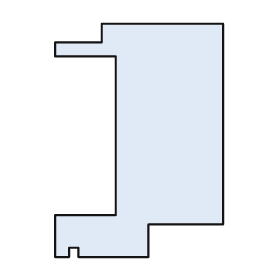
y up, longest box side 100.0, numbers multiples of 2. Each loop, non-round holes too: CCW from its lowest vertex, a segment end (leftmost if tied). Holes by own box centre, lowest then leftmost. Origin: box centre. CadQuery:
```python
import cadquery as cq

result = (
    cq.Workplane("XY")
    .moveTo(-36.0, -50.0)
    .lineTo(-30.0, -50.0)
    .lineTo(-30.0, -46.0)
    .lineTo(-26.0, -46.0)
    .lineTo(-26.0, -50.0)
    .lineTo(4.0, -50.0)
    .lineTo(4.0, -36.0)
    .lineTo(36.0, -36.0)
    .lineTo(36.0, 50.0)
    .lineTo(-16.0, 50.0)
    .lineTo(-16.0, 42.0)
    .lineTo(-36.0, 42.0)
    .lineTo(-36.0, 36.0)
    .lineTo(-10.0, 36.0)
    .lineTo(-10.0, -32.0)
    .lineTo(-36.0, -32.0)
    .close()
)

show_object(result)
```